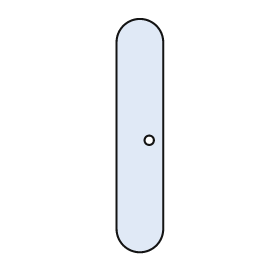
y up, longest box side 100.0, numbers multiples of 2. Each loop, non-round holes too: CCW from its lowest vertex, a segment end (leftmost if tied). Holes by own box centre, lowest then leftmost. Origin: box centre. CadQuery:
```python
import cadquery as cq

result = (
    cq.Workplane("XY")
    .moveTo(-10.0, -40.0)
    .threePointArc((0.0, -50.0), (10.0, -40.0))
    .lineTo(10.0, 40.0)
    .threePointArc((0.0, 50.0), (-10.0, 40.0))
    .close()
    .moveTo(4.0, -2.0)
    .circle(2.0)
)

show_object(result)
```